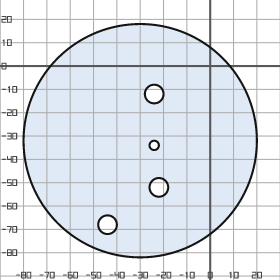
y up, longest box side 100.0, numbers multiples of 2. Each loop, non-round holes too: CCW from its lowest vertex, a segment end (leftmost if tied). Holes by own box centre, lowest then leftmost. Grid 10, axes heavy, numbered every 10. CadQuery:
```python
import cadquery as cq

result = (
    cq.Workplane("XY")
    .moveTo(-30.0, -32.0)
    .circle(50.0)
    .moveTo(-44.0, -68.0)
    .circle(4.0)
    .moveTo(-22.0, -52.0)
    .circle(4.0)
    .moveTo(-24.0, -34.0)
    .circle(2.0)
    .moveTo(-24.0, -12.0)
    .circle(4.0)
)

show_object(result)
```